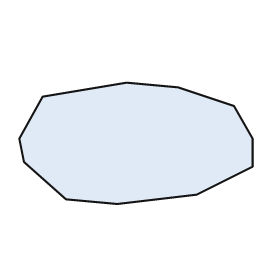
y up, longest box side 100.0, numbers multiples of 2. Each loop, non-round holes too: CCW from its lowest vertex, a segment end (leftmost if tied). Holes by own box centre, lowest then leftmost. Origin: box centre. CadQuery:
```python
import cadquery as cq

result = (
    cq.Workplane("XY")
    .moveTo(-8.0, -26.0)
    .lineTo(26.0, -22.0)
    .lineTo(50.0, -10.0)
    .lineTo(50.0, 2.0)
    .lineTo(42.0, 16.0)
    .lineTo(18.0, 24.0)
    .lineTo(-4.0, 26.0)
    .lineTo(-40.0, 20.0)
    .lineTo(-50.0, 2.0)
    .lineTo(-48.0, -8.0)
    .lineTo(-30.0, -24.0)
    .close()
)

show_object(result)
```